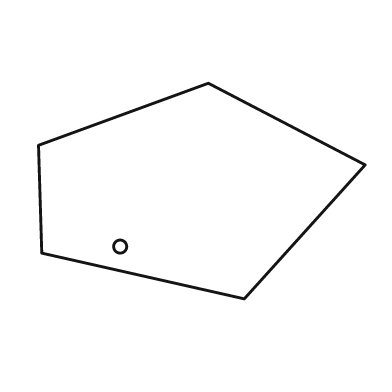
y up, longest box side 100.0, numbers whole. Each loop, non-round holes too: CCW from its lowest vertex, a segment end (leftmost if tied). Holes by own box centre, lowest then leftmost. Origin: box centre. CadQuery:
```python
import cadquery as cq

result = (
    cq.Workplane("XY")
    .moveTo(13.0, -33.0)
    .lineTo(50.0, 8.0)
    .lineTo(2.0, 33.0)
    .lineTo(-50.0, 14.0)
    .lineTo(-49.0, -19.0)
    .close()
    .moveTo(-25.0, -17.0)
    .circle(2.0)
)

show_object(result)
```